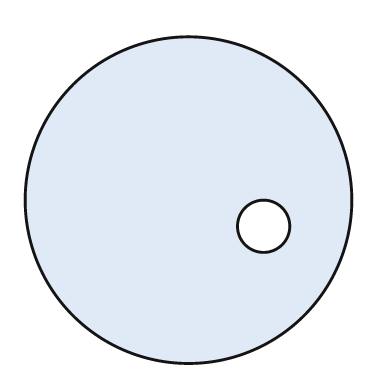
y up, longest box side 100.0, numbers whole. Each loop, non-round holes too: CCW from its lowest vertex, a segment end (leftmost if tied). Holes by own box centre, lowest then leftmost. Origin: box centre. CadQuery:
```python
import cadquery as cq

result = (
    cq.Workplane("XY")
    .moveTo(0.0, 0.0)
    .circle(50.0)
    .moveTo(23.0, -8.0)
    .circle(8.0)
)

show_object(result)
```